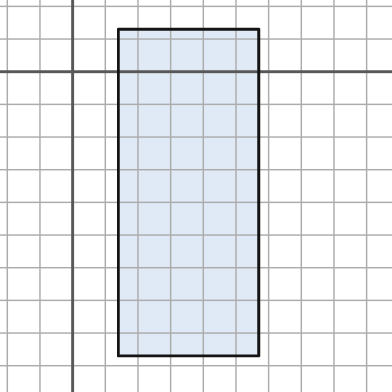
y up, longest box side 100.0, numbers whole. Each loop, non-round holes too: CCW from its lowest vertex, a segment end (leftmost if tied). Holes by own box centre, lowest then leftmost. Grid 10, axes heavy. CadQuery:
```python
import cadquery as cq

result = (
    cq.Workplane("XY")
    .moveTo(14.0, -87.0)
    .lineTo(57.0, -87.0)
    .lineTo(57.0, 13.0)
    .lineTo(14.0, 13.0)
    .close()
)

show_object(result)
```